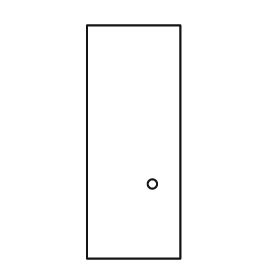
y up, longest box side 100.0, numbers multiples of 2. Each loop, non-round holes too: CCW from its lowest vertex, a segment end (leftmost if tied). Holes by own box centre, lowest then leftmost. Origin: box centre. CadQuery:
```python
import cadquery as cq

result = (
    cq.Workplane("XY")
    .moveTo(-20.0, -50.0)
    .lineTo(20.0, -50.0)
    .lineTo(20.0, 50.0)
    .lineTo(-20.0, 50.0)
    .close()
    .moveTo(8.0, -18.0)
    .circle(2.0)
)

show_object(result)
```